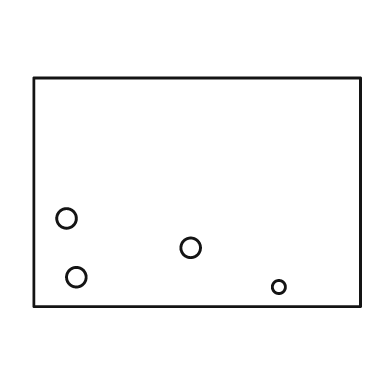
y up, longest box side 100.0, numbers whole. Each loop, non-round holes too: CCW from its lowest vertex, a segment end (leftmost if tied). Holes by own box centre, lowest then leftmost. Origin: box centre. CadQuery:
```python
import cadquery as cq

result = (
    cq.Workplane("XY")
    .moveTo(-50.0, -35.0)
    .lineTo(50.0, -35.0)
    .lineTo(50.0, 35.0)
    .lineTo(-50.0, 35.0)
    .close()
    .moveTo(25.0, -29.0)
    .circle(2.0)
    .moveTo(-37.0, -26.0)
    .circle(3.0)
    .moveTo(-2.0, -17.0)
    .circle(3.0)
    .moveTo(-40.0, -8.0)
    .circle(3.0)
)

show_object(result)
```